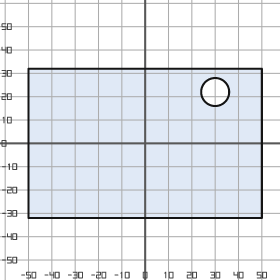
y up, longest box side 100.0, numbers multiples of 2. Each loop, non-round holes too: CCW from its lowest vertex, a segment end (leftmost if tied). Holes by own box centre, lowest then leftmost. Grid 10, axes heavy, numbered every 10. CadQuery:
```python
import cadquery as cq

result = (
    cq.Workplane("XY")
    .moveTo(-50.0, -32.0)
    .lineTo(50.0, -32.0)
    .lineTo(50.0, 32.0)
    .lineTo(-50.0, 32.0)
    .close()
    .moveTo(30.0, 22.0)
    .circle(6.0)
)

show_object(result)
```